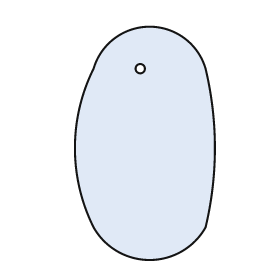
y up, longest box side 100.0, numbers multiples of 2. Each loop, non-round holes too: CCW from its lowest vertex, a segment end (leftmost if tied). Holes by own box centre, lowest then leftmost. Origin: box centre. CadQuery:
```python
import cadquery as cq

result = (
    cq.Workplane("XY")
    .moveTo(-22.0, -36.0)
    .threePointArc((2.0, -50.0), (26.0, -36.0))
    .threePointArc((30.0, -2.0), (26.0, 32.0))
    .threePointArc((2.0, 50.0), (-22.0, 32.0))
    .threePointArc((-30.0, -2.0), (-22.0, -36.0))
    .close()
    .moveTo(-2.0, 32.0)
    .circle(2.0)
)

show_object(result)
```